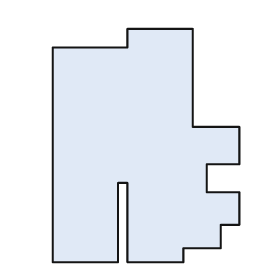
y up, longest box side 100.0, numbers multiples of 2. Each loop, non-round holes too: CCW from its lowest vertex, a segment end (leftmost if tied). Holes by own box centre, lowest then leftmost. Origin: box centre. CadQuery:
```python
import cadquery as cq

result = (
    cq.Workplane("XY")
    .moveTo(-40.0, -50.0)
    .lineTo(-12.0, -50.0)
    .lineTo(-12.0, -16.0)
    .lineTo(-8.0, -16.0)
    .lineTo(-8.0, -50.0)
    .lineTo(16.0, -50.0)
    .lineTo(16.0, -44.0)
    .lineTo(32.0, -44.0)
    .lineTo(32.0, -34.0)
    .lineTo(40.0, -34.0)
    .lineTo(40.0, -20.0)
    .lineTo(26.0, -20.0)
    .lineTo(26.0, -8.0)
    .lineTo(40.0, -8.0)
    .lineTo(40.0, 8.0)
    .lineTo(20.0, 8.0)
    .lineTo(20.0, 50.0)
    .lineTo(-8.0, 50.0)
    .lineTo(-8.0, 42.0)
    .lineTo(-40.0, 42.0)
    .close()
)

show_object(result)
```